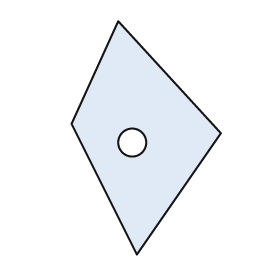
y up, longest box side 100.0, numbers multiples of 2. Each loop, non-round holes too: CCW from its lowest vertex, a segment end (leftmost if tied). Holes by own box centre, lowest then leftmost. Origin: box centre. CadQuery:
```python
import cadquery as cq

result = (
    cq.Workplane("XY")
    .moveTo(-4.0, -50.0)
    .lineTo(32.0, 2.0)
    .lineTo(-12.0, 50.0)
    .lineTo(-32.0, 6.0)
    .close()
    .moveTo(-6.0, -2.0)
    .circle(6.0)
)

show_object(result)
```